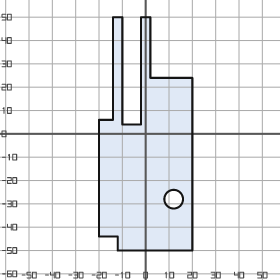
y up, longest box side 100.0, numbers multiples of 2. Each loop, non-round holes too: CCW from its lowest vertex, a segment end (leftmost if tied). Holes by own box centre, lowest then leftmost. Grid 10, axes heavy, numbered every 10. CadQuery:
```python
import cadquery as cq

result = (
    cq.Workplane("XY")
    .moveTo(-12.0, -50.0)
    .lineTo(20.0, -50.0)
    .lineTo(20.0, 24.0)
    .lineTo(2.0, 24.0)
    .lineTo(2.0, 50.0)
    .lineTo(-2.0, 50.0)
    .lineTo(-2.0, 4.0)
    .lineTo(-10.0, 4.0)
    .lineTo(-10.0, 50.0)
    .lineTo(-14.0, 50.0)
    .lineTo(-14.0, 6.0)
    .lineTo(-20.0, 6.0)
    .lineTo(-20.0, -44.0)
    .lineTo(-12.0, -44.0)
    .close()
    .moveTo(12.0, -28.0)
    .circle(4.0)
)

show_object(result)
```